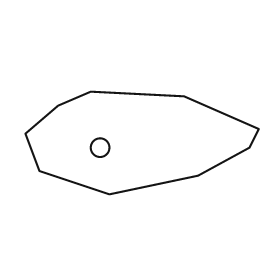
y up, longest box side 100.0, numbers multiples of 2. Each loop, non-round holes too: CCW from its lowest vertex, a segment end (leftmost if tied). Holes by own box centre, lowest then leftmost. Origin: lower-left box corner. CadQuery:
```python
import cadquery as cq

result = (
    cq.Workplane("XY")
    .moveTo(36.0, 0.0)
    .lineTo(74.0, 8.0)
    .lineTo(96.0, 20.0)
    .lineTo(100.0, 28.0)
    .lineTo(68.0, 42.0)
    .lineTo(28.0, 44.0)
    .lineTo(14.0, 38.0)
    .lineTo(0.0, 26.0)
    .lineTo(6.0, 10.0)
    .close()
    .moveTo(32.0, 20.0)
    .circle(4.0)
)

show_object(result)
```